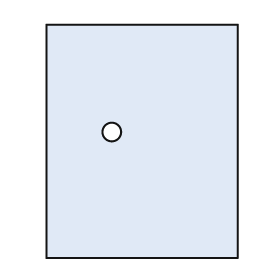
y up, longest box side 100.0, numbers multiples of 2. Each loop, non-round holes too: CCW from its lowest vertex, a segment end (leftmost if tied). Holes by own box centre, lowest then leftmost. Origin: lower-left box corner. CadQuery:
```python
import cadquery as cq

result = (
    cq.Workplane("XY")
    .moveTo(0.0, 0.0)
    .lineTo(82.0, 0.0)
    .lineTo(82.0, 100.0)
    .lineTo(0.0, 100.0)
    .close()
    .moveTo(28.0, 54.0)
    .circle(4.0)
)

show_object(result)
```